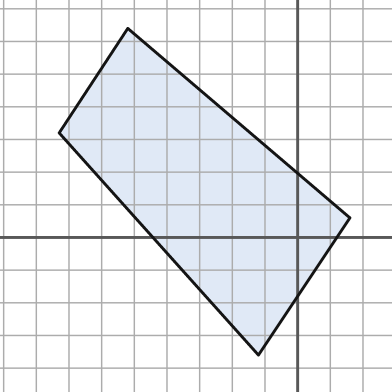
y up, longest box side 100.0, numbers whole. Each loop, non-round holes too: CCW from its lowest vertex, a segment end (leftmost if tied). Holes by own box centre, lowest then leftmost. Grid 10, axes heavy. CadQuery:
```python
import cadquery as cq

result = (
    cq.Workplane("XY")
    .moveTo(-12.0, -36.0)
    .lineTo(16.0, 6.0)
    .lineTo(-52.0, 64.0)
    .lineTo(-73.0, 32.0)
    .close()
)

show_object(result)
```